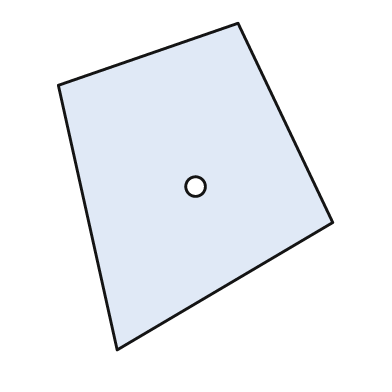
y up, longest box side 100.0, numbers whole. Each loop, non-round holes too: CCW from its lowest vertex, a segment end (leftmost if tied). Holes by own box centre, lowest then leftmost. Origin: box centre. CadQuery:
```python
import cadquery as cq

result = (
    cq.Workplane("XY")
    .moveTo(-24.0, -50.0)
    .lineTo(42.0, -11.0)
    .lineTo(13.0, 50.0)
    .lineTo(-42.0, 31.0)
    .close()
    .moveTo(0.0, 0.0)
    .circle(3.0)
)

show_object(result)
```